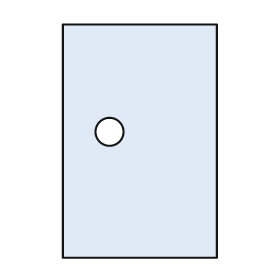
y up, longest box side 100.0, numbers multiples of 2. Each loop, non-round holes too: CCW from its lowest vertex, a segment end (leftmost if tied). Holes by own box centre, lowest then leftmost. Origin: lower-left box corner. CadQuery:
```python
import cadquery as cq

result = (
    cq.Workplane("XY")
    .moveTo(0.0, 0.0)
    .lineTo(66.0, 0.0)
    .lineTo(66.0, 100.0)
    .lineTo(0.0, 100.0)
    .close()
    .moveTo(20.0, 54.0)
    .circle(6.0)
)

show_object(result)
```